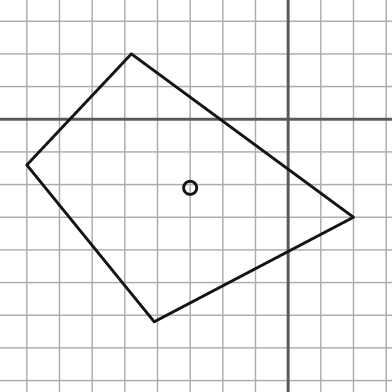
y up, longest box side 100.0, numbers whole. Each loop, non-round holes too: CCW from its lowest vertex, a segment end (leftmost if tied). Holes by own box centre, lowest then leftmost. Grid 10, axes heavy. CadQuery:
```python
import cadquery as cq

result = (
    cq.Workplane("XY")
    .moveTo(-41.0, -62.0)
    .lineTo(20.0, -30.0)
    .lineTo(-48.0, 20.0)
    .lineTo(-80.0, -14.0)
    .close()
    .moveTo(-30.0, -21.0)
    .circle(2.0)
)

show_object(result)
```